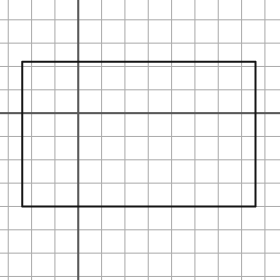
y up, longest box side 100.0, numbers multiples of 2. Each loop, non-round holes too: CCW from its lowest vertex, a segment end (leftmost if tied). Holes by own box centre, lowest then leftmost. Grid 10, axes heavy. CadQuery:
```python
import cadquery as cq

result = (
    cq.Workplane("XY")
    .moveTo(-24.0, -40.0)
    .lineTo(76.0, -40.0)
    .lineTo(76.0, 22.0)
    .lineTo(-24.0, 22.0)
    .close()
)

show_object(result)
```